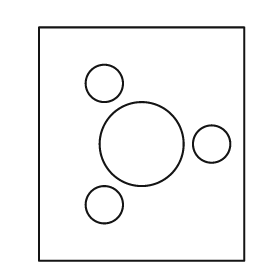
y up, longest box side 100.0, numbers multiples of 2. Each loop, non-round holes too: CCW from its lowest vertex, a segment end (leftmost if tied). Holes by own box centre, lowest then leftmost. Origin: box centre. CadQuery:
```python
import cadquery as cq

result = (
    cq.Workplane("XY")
    .moveTo(-44.0, -50.0)
    .lineTo(44.0, -50.0)
    .lineTo(44.0, 50.0)
    .lineTo(-44.0, 50.0)
    .close()
    .moveTo(-16.0, -26.0)
    .circle(8.0)
    .moveTo(0.0, 0.0)
    .circle(18.0)
    .moveTo(30.0, 0.0)
    .circle(8.0)
    .moveTo(-16.0, 26.0)
    .circle(8.0)
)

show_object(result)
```